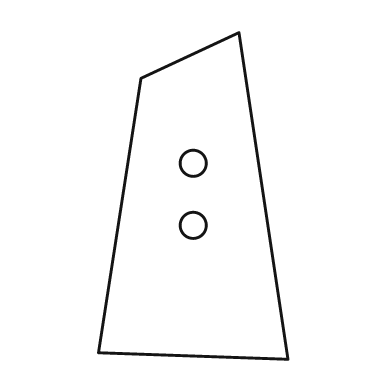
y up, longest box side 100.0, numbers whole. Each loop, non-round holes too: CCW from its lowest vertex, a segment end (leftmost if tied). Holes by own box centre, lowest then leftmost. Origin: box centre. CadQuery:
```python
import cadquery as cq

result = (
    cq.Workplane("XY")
    .moveTo(29.0, -50.0)
    .lineTo(14.0, 50.0)
    .lineTo(-16.0, 36.0)
    .lineTo(-29.0, -48.0)
    .close()
    .moveTo(0.0, -9.0)
    .circle(4.0)
    .moveTo(0.0, 10.0)
    .circle(4.0)
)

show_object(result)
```